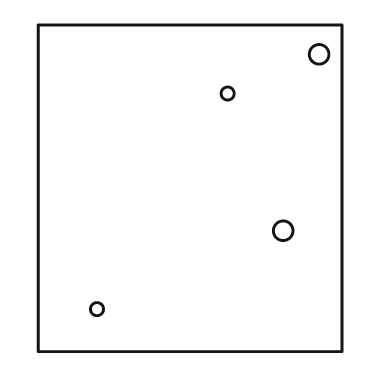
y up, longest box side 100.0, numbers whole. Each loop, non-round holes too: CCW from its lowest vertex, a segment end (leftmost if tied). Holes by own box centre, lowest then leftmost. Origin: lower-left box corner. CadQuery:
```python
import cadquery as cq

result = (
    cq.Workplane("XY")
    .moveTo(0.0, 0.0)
    .lineTo(93.0, 0.0)
    .lineTo(93.0, 100.0)
    .lineTo(0.0, 100.0)
    .close()
    .moveTo(18.0, 13.0)
    .circle(2.0)
    .moveTo(75.0, 37.0)
    .circle(3.0)
    .moveTo(58.0, 79.0)
    .circle(2.0)
    .moveTo(86.0, 91.0)
    .circle(3.0)
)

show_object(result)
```